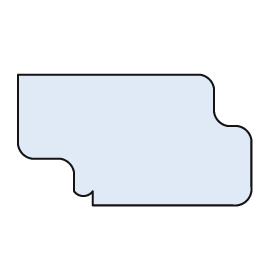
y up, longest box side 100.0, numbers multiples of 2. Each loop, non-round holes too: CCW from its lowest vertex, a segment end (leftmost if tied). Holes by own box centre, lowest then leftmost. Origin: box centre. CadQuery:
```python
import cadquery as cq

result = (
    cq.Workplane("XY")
    .moveTo(-18.0, -28.0)
    .lineTo(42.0, -28.0)
    .threePointArc((48.0, -26.0), (50.0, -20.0))
    .lineTo(50.0, 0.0)
    .threePointArc((48.0, 4.0), (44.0, 6.0))
    .lineTo(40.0, 6.0)
    .threePointArc((36.0, 8.0), (34.0, 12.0))
    .lineTo(34.0, 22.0)
    .threePointArc((32.0, 26.0), (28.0, 28.0))
    .lineTo(-50.0, 28.0)
    .lineTo(-50.0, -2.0)
    .threePointArc((-48.0, -6.0), (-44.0, -8.0))
    .lineTo(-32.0, -8.0)
    .threePointArc((-28.0, -10.0), (-26.0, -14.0))
    .lineTo(-26.0, -22.0)
    .threePointArc((-22.0, -24.0), (-18.0, -22.0))
    .close()
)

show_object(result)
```